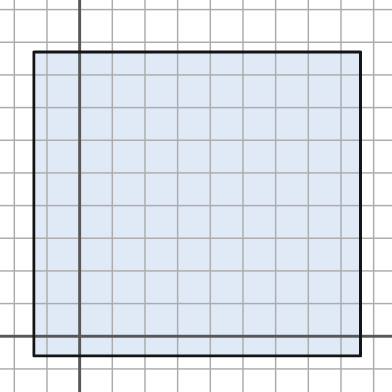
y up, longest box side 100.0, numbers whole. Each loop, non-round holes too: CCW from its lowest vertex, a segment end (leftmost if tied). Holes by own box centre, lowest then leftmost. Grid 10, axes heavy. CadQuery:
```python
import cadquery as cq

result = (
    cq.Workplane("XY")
    .moveTo(-14.0, -6.0)
    .lineTo(86.0, -6.0)
    .lineTo(86.0, 87.0)
    .lineTo(-14.0, 87.0)
    .close()
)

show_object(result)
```